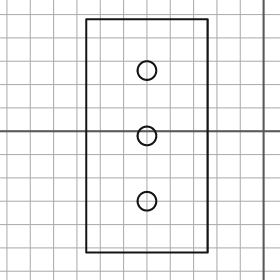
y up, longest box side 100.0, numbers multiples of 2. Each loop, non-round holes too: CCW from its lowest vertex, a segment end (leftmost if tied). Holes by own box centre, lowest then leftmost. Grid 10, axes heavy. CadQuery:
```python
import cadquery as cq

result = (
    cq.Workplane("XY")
    .moveTo(-76.0, -52.0)
    .lineTo(-24.0, -52.0)
    .lineTo(-24.0, 48.0)
    .lineTo(-76.0, 48.0)
    .close()
    .moveTo(-50.0, -30.0)
    .circle(4.0)
    .moveTo(-50.0, -2.0)
    .circle(4.0)
    .moveTo(-50.0, 26.0)
    .circle(4.0)
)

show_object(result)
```